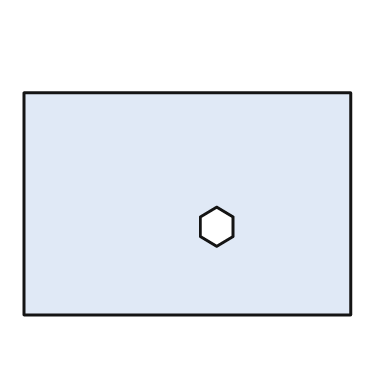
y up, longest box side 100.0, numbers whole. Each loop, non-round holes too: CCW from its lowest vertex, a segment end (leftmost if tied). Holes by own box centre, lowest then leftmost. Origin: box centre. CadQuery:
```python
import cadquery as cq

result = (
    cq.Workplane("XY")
    .moveTo(-50.0, -34.0)
    .lineTo(50.0, -34.0)
    .lineTo(50.0, 34.0)
    .lineTo(-50.0, 34.0)
    .close()
    .moveTo(9.0, -13.0)
    .lineTo(14.0, -10.0)
    .lineTo(14.0, -4.0)
    .lineTo(9.0, -1.0)
    .lineTo(4.0, -4.0)
    .lineTo(4.0, -10.0)
    .close()
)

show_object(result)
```